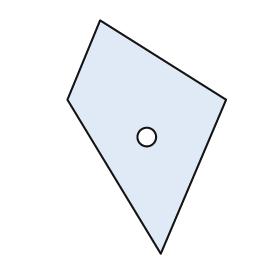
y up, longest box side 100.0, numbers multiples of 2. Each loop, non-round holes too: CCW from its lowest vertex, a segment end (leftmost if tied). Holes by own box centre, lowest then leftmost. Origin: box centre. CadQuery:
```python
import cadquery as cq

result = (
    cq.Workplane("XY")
    .moveTo(6.0, -50.0)
    .lineTo(34.0, 16.0)
    .lineTo(-20.0, 50.0)
    .lineTo(-34.0, 16.0)
    .close()
    .moveTo(0.0, 0.0)
    .circle(4.0)
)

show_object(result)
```